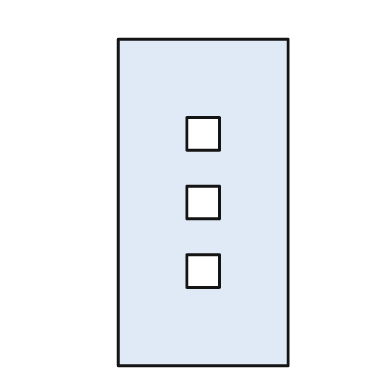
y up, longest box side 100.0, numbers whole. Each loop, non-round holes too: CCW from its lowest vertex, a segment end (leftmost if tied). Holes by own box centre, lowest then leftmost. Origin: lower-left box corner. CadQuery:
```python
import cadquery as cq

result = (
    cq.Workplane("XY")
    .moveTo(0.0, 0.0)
    .lineTo(52.0, 0.0)
    .lineTo(52.0, 100.0)
    .lineTo(0.0, 100.0)
    .close()
    .moveTo(21.0, 24.0)
    .lineTo(31.0, 24.0)
    .lineTo(31.0, 34.0)
    .lineTo(21.0, 34.0)
    .close()
    .moveTo(21.0, 45.0)
    .lineTo(31.0, 45.0)
    .lineTo(31.0, 55.0)
    .lineTo(21.0, 55.0)
    .close()
    .moveTo(21.0, 66.0)
    .lineTo(31.0, 66.0)
    .lineTo(31.0, 76.0)
    .lineTo(21.0, 76.0)
    .close()
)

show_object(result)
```